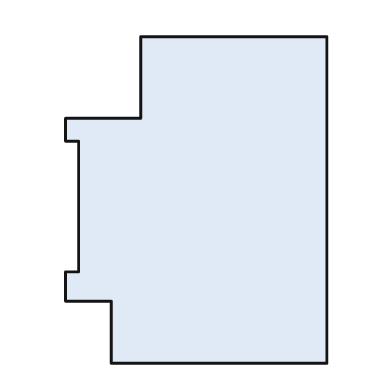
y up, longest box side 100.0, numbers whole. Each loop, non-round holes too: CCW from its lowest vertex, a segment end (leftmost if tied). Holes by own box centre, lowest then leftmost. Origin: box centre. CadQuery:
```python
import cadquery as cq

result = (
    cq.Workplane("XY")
    .moveTo(-26.0, -50.0)
    .lineTo(40.0, -50.0)
    .lineTo(40.0, 50.0)
    .lineTo(-17.0, 50.0)
    .lineTo(-17.0, 25.0)
    .lineTo(-40.0, 25.0)
    .lineTo(-40.0, 18.0)
    .lineTo(-36.0, 18.0)
    .lineTo(-36.0, -22.0)
    .lineTo(-40.0, -22.0)
    .lineTo(-40.0, -31.0)
    .lineTo(-26.0, -31.0)
    .close()
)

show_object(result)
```